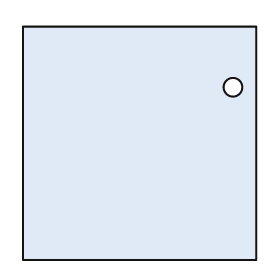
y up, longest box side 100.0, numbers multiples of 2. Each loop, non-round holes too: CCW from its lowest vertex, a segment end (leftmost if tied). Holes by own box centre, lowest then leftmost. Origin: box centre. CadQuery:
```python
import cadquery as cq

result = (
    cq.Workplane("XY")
    .moveTo(-50.0, -50.0)
    .lineTo(50.0, -50.0)
    .lineTo(50.0, 50.0)
    .lineTo(-50.0, 50.0)
    .close()
    .moveTo(40.0, 24.0)
    .circle(4.0)
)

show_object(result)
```